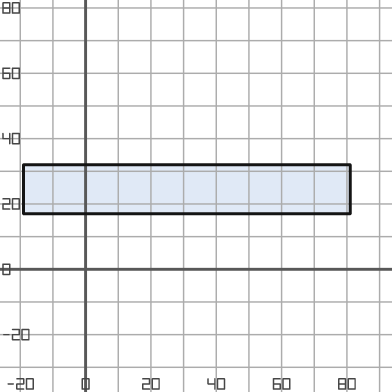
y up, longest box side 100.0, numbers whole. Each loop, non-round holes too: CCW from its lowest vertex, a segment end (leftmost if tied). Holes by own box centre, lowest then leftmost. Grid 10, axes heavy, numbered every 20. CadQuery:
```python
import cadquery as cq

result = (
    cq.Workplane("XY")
    .moveTo(-19.0, 17.0)
    .lineTo(81.0, 17.0)
    .lineTo(81.0, 32.0)
    .lineTo(-19.0, 32.0)
    .close()
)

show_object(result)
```